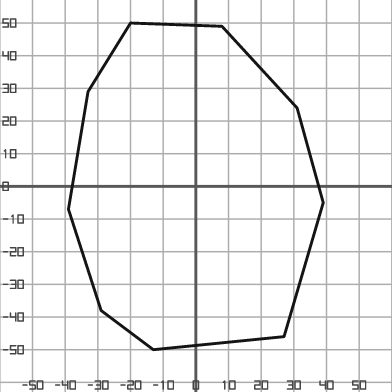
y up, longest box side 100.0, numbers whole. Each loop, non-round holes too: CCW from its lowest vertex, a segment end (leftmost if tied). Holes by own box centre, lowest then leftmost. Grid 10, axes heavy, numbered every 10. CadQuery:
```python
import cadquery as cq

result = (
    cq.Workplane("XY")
    .moveTo(-13.0, -50.0)
    .lineTo(27.0, -46.0)
    .lineTo(39.0, -5.0)
    .lineTo(31.0, 24.0)
    .lineTo(8.0, 49.0)
    .lineTo(-20.0, 50.0)
    .lineTo(-33.0, 29.0)
    .lineTo(-39.0, -7.0)
    .lineTo(-29.0, -38.0)
    .close()
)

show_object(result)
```